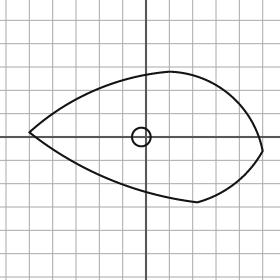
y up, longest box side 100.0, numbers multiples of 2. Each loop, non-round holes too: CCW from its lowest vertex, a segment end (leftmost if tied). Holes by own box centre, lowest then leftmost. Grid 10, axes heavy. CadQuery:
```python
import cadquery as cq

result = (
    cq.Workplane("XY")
    .moveTo(22.0, -28.0)
    .threePointArc((38.0, -20.0), (50.0, -6.0))
    .threePointArc((36.0, 18.0), (10.0, 28.0))
    .threePointArc((-22.0, 20.0), (-50.0, 2.0))
    .threePointArc((-16.0, -18.0), (22.0, -28.0))
    .close()
    .moveTo(-2.0, 0.0)
    .circle(4.0)
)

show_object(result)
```